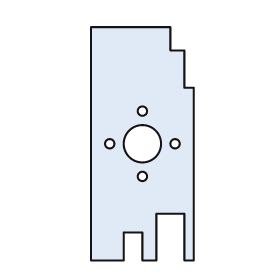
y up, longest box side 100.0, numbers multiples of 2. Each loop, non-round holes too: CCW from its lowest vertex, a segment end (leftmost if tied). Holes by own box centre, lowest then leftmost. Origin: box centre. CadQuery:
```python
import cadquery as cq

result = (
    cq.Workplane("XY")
    .moveTo(-22.0, -50.0)
    .lineTo(-8.0, -50.0)
    .lineTo(-8.0, -38.0)
    .lineTo(0.0, -38.0)
    .lineTo(0.0, -50.0)
    .lineTo(6.0, -50.0)
    .lineTo(6.0, -30.0)
    .lineTo(18.0, -30.0)
    .lineTo(18.0, -50.0)
    .lineTo(22.0, -50.0)
    .lineTo(22.0, 24.0)
    .lineTo(18.0, 24.0)
    .lineTo(18.0, 40.0)
    .lineTo(12.0, 40.0)
    .lineTo(12.0, 50.0)
    .lineTo(-22.0, 50.0)
    .close()
    .moveTo(0.0, -14.0)
    .circle(2.0)
    .moveTo(-14.0, 0.0)
    .circle(2.0)
    .moveTo(0.0, 0.0)
    .circle(8.0)
    .moveTo(14.0, 0.0)
    .circle(2.0)
    .moveTo(0.0, 14.0)
    .circle(2.0)
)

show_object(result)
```